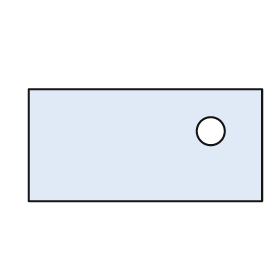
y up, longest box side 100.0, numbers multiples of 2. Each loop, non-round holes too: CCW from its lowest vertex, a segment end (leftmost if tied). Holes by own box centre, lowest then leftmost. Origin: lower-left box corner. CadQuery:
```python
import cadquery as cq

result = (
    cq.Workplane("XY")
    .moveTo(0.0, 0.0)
    .lineTo(100.0, 0.0)
    .lineTo(100.0, 48.0)
    .lineTo(0.0, 48.0)
    .close()
    .moveTo(78.0, 30.0)
    .circle(6.0)
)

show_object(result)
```